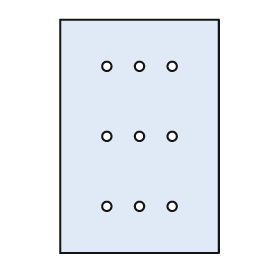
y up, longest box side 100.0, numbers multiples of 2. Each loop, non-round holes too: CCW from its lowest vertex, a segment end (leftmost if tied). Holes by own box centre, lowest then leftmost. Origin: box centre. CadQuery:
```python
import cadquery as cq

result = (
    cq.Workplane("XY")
    .moveTo(-34.0, -50.0)
    .lineTo(34.0, -50.0)
    .lineTo(34.0, 50.0)
    .lineTo(-34.0, 50.0)
    .close()
    .moveTo(-14.0, -30.0)
    .circle(2.0)
    .moveTo(0.0, -30.0)
    .circle(2.0)
    .moveTo(14.0, -30.0)
    .circle(2.0)
    .moveTo(-14.0, 0.0)
    .circle(2.0)
    .moveTo(0.0, 0.0)
    .circle(2.0)
    .moveTo(14.0, 0.0)
    .circle(2.0)
    .moveTo(-14.0, 30.0)
    .circle(2.0)
    .moveTo(0.0, 30.0)
    .circle(2.0)
    .moveTo(14.0, 30.0)
    .circle(2.0)
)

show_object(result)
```